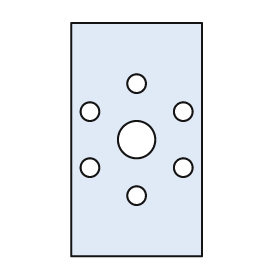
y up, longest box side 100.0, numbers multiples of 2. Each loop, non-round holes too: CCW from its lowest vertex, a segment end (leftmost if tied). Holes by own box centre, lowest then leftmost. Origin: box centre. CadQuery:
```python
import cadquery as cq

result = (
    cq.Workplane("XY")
    .moveTo(-28.0, -50.0)
    .lineTo(28.0, -50.0)
    .lineTo(28.0, 50.0)
    .lineTo(-28.0, 50.0)
    .close()
    .moveTo(0.0, -24.0)
    .circle(4.0)
    .moveTo(-20.0, -12.0)
    .circle(4.0)
    .moveTo(20.0, -12.0)
    .circle(4.0)
    .moveTo(0.0, 0.0)
    .circle(8.0)
    .moveTo(-20.0, 12.0)
    .circle(4.0)
    .moveTo(20.0, 12.0)
    .circle(4.0)
    .moveTo(0.0, 24.0)
    .circle(4.0)
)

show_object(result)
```